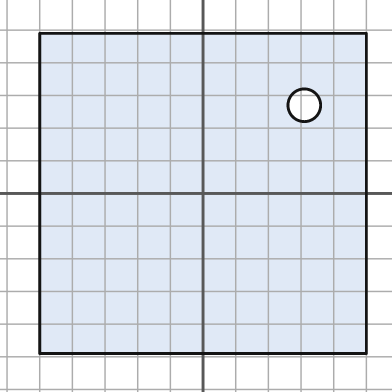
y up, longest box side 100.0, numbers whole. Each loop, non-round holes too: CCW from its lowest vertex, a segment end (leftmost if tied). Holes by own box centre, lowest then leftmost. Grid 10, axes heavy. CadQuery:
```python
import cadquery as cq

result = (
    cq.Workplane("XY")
    .moveTo(-50.0, -49.0)
    .lineTo(50.0, -49.0)
    .lineTo(50.0, 49.0)
    .lineTo(-50.0, 49.0)
    .close()
    .moveTo(31.0, 27.0)
    .circle(5.0)
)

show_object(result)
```